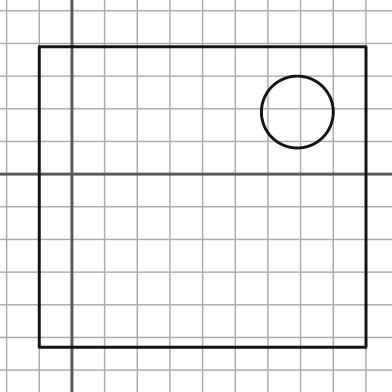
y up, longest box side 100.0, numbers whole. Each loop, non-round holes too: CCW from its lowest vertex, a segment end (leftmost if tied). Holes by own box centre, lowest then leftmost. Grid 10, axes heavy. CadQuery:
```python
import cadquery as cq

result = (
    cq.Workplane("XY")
    .moveTo(-10.0, -53.0)
    .lineTo(90.0, -53.0)
    .lineTo(90.0, 39.0)
    .lineTo(-10.0, 39.0)
    .close()
    .moveTo(69.0, 19.0)
    .circle(11.0)
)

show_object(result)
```